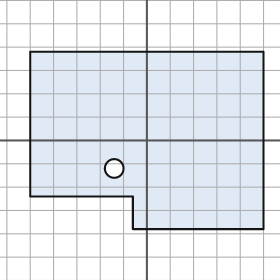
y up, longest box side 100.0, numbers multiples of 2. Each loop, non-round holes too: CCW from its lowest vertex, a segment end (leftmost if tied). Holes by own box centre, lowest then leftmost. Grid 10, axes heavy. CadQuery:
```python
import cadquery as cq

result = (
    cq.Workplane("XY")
    .moveTo(-6.0, -38.0)
    .lineTo(50.0, -38.0)
    .lineTo(50.0, 38.0)
    .lineTo(-50.0, 38.0)
    .lineTo(-50.0, -24.0)
    .lineTo(-6.0, -24.0)
    .close()
    .moveTo(-14.0, -12.0)
    .circle(4.0)
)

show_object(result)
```